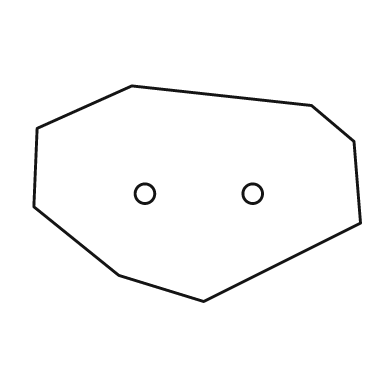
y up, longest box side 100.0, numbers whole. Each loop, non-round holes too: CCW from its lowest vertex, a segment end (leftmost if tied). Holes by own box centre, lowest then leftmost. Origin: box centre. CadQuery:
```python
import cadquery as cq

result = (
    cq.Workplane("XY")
    .moveTo(2.0, -33.0)
    .lineTo(50.0, -9.0)
    .lineTo(48.0, 16.0)
    .lineTo(35.0, 27.0)
    .lineTo(-20.0, 33.0)
    .lineTo(-49.0, 20.0)
    .lineTo(-50.0, -4.0)
    .lineTo(-24.0, -25.0)
    .close()
    .moveTo(-16.0, 0.0)
    .circle(3.0)
    .moveTo(17.0, 0.0)
    .circle(3.0)
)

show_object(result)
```